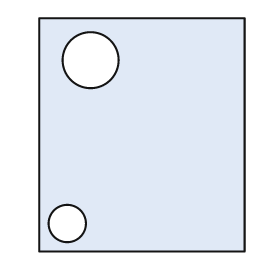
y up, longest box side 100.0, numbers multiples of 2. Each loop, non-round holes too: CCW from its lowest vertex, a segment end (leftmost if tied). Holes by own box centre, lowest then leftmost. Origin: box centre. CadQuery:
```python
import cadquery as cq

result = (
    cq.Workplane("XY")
    .moveTo(-44.0, -50.0)
    .lineTo(44.0, -50.0)
    .lineTo(44.0, 50.0)
    .lineTo(-44.0, 50.0)
    .close()
    .moveTo(-32.0, -38.0)
    .circle(8.0)
    .moveTo(-22.0, 32.0)
    .circle(12.0)
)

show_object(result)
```